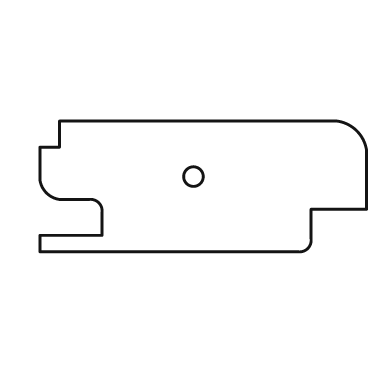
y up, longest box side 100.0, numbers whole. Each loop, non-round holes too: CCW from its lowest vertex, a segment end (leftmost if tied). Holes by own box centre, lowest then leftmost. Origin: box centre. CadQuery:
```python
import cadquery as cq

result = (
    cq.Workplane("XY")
    .moveTo(-50.0, -20.0)
    .lineTo(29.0, -20.0)
    .threePointArc((32.0, -19.0), (33.0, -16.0))
    .lineTo(33.0, -7.0)
    .lineTo(50.0, -7.0)
    .lineTo(50.0, 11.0)
    .threePointArc((47.0, 17.0), (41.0, 20.0))
    .lineTo(-44.0, 20.0)
    .lineTo(-44.0, 12.0)
    .lineTo(-50.0, 12.0)
    .lineTo(-50.0, 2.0)
    .threePointArc((-48.0, -2.0), (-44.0, -4.0))
    .lineTo(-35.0, -4.0)
    .threePointArc((-32.0, -5.0), (-31.0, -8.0))
    .lineTo(-31.0, -15.0)
    .lineTo(-50.0, -15.0)
    .close()
    .moveTo(-3.0, 3.0)
    .circle(3.0)
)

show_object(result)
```